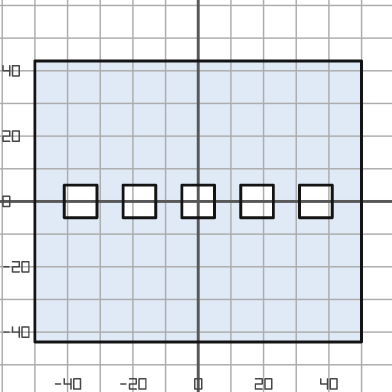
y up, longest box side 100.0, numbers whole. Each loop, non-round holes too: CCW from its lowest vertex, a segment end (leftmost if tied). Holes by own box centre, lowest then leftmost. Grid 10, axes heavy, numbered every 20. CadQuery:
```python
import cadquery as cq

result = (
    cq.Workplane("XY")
    .moveTo(-50.0, -43.0)
    .lineTo(50.0, -43.0)
    .lineTo(50.0, 43.0)
    .lineTo(-50.0, 43.0)
    .close()
    .moveTo(-41.0, -5.0)
    .lineTo(-31.0, -5.0)
    .lineTo(-31.0, 5.0)
    .lineTo(-41.0, 5.0)
    .close()
    .moveTo(-23.0, -5.0)
    .lineTo(-13.0, -5.0)
    .lineTo(-13.0, 5.0)
    .lineTo(-23.0, 5.0)
    .close()
    .moveTo(-5.0, -5.0)
    .lineTo(5.0, -5.0)
    .lineTo(5.0, 5.0)
    .lineTo(-5.0, 5.0)
    .close()
    .moveTo(13.0, -5.0)
    .lineTo(23.0, -5.0)
    .lineTo(23.0, 5.0)
    .lineTo(13.0, 5.0)
    .close()
    .moveTo(31.0, -5.0)
    .lineTo(41.0, -5.0)
    .lineTo(41.0, 5.0)
    .lineTo(31.0, 5.0)
    .close()
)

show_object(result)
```